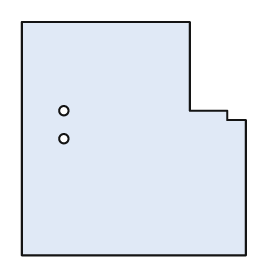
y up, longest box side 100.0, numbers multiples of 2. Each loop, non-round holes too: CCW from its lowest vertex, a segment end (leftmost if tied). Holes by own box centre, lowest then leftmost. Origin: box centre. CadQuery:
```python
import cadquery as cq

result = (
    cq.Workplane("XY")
    .moveTo(-48.0, -50.0)
    .lineTo(48.0, -50.0)
    .lineTo(48.0, 8.0)
    .lineTo(40.0, 8.0)
    .lineTo(40.0, 12.0)
    .lineTo(24.0, 12.0)
    .lineTo(24.0, 50.0)
    .lineTo(-48.0, 50.0)
    .close()
    .moveTo(-30.0, 0.0)
    .circle(2.0)
    .moveTo(-30.0, 12.0)
    .circle(2.0)
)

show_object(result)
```